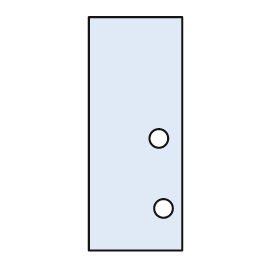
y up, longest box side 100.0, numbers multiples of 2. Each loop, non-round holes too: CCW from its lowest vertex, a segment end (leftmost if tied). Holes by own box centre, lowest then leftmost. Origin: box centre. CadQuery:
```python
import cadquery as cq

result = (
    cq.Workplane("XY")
    .moveTo(-20.0, -50.0)
    .lineTo(20.0, -50.0)
    .lineTo(20.0, 50.0)
    .lineTo(-20.0, 50.0)
    .close()
    .moveTo(12.0, -32.0)
    .circle(4.0)
    .moveTo(10.0, -2.0)
    .circle(4.0)
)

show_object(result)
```